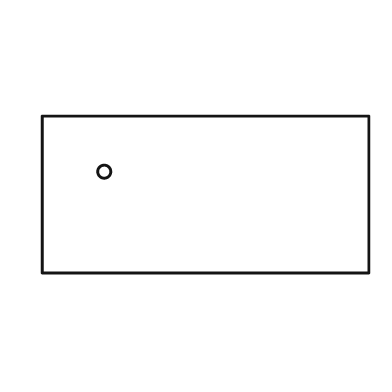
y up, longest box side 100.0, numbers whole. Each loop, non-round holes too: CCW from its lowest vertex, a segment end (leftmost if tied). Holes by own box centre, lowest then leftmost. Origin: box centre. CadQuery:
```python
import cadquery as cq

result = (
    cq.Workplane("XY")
    .moveTo(-50.0, -24.0)
    .lineTo(50.0, -24.0)
    .lineTo(50.0, 24.0)
    .lineTo(-50.0, 24.0)
    .close()
    .moveTo(-31.0, 7.0)
    .circle(2.0)
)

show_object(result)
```